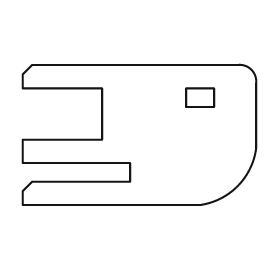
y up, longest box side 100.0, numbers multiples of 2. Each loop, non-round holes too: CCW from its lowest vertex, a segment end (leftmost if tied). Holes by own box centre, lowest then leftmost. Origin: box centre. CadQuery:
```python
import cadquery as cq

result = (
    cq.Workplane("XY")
    .moveTo(-50.0, -30.0)
    .lineTo(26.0, -30.0)
    .threePointArc((42.0, -22.0), (50.0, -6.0))
    .lineTo(50.0, 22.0)
    .threePointArc((48.0, 28.0), (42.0, 30.0))
    .lineTo(-46.0, 30.0)
    .lineTo(-50.0, 26.0)
    .lineTo(-50.0, 20.0)
    .lineTo(-16.0, 20.0)
    .lineTo(-16.0, -2.0)
    .lineTo(-50.0, -2.0)
    .lineTo(-50.0, -12.0)
    .lineTo(-4.0, -12.0)
    .lineTo(-4.0, -20.0)
    .lineTo(-46.0, -20.0)
    .lineTo(-50.0, -24.0)
    .close()
    .moveTo(20.0, 12.0)
    .lineTo(32.0, 12.0)
    .lineTo(32.0, 20.0)
    .lineTo(20.0, 20.0)
    .close()
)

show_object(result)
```